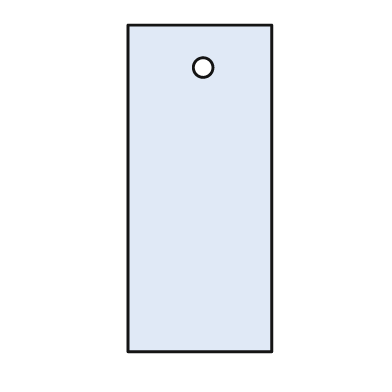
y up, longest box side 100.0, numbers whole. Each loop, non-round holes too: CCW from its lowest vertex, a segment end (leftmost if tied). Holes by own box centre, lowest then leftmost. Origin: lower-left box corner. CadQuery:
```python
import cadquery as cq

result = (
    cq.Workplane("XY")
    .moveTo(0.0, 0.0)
    .lineTo(44.0, 0.0)
    .lineTo(44.0, 100.0)
    .lineTo(0.0, 100.0)
    .close()
    .moveTo(23.0, 87.0)
    .circle(3.0)
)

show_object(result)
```